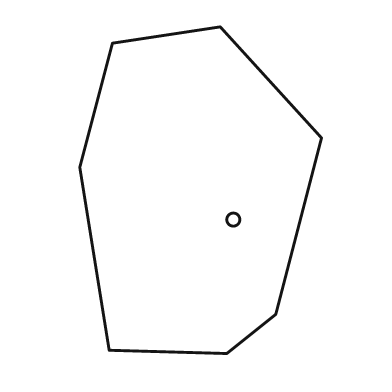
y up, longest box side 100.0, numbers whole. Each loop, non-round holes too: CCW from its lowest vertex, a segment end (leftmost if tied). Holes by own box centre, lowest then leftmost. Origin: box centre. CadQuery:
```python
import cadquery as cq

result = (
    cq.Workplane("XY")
    .moveTo(8.0, -50.0)
    .lineTo(23.0, -38.0)
    .lineTo(37.0, 16.0)
    .lineTo(6.0, 50.0)
    .lineTo(-27.0, 45.0)
    .lineTo(-37.0, 7.0)
    .lineTo(-28.0, -49.0)
    .close()
    .moveTo(10.0, -9.0)
    .circle(2.0)
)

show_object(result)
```